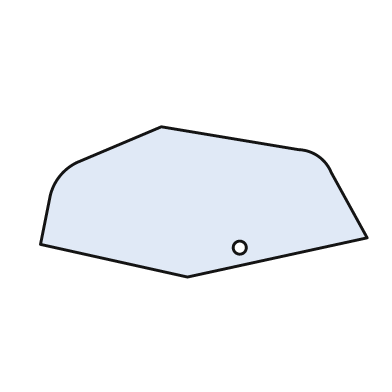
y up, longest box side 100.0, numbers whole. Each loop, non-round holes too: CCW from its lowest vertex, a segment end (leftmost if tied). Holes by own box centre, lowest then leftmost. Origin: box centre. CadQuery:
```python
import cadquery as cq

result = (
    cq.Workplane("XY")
    .moveTo(-5.0, -23.0)
    .lineTo(50.0, -11.0)
    .lineTo(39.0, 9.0)
    .threePointArc((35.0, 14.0), (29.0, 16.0))
    .lineTo(-13.0, 23.0)
    .lineTo(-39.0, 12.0)
    .threePointArc((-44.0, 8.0), (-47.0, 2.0))
    .lineTo(-50.0, -13.0)
    .close()
    .moveTo(11.0, -14.0)
    .circle(2.0)
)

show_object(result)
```